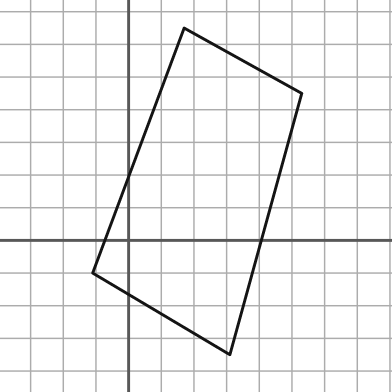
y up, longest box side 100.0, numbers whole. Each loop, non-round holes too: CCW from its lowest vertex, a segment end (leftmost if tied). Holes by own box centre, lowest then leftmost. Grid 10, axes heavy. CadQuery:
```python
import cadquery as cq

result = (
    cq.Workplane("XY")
    .moveTo(31.0, -35.0)
    .lineTo(53.0, 45.0)
    .lineTo(17.0, 65.0)
    .lineTo(-11.0, -10.0)
    .close()
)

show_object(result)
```